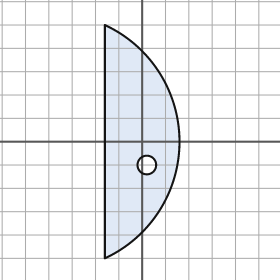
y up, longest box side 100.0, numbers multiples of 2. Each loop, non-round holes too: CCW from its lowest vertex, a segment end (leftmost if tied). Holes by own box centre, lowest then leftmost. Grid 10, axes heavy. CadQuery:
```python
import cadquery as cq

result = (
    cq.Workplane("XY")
    .moveTo(-16.0, -50.0)
    .threePointArc((16.0, 0.0), (-16.0, 50.0))
    .close()
    .moveTo(2.0, -10.0)
    .circle(4.0)
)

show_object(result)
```